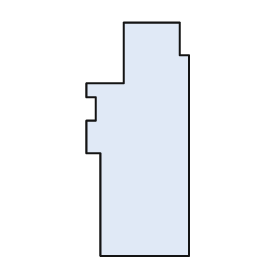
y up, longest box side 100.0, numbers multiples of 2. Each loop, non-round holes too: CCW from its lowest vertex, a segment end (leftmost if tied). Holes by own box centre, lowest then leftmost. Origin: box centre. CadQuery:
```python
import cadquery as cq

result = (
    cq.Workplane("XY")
    .moveTo(-16.0, -50.0)
    .lineTo(22.0, -50.0)
    .lineTo(22.0, 36.0)
    .lineTo(18.0, 36.0)
    .lineTo(18.0, 50.0)
    .lineTo(-6.0, 50.0)
    .lineTo(-6.0, 24.0)
    .lineTo(-22.0, 24.0)
    .lineTo(-22.0, 18.0)
    .lineTo(-18.0, 18.0)
    .lineTo(-18.0, 8.0)
    .lineTo(-22.0, 8.0)
    .lineTo(-22.0, -6.0)
    .lineTo(-16.0, -6.0)
    .close()
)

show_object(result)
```